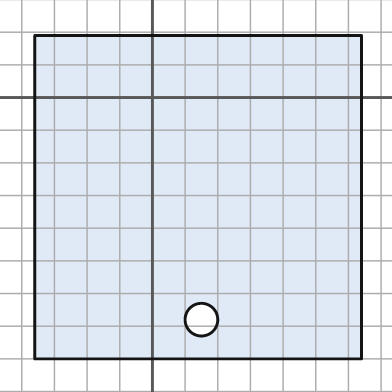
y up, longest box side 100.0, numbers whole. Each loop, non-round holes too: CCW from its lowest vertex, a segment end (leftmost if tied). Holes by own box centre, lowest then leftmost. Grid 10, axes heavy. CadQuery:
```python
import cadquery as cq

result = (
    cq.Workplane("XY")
    .moveTo(-36.0, -80.0)
    .lineTo(64.0, -80.0)
    .lineTo(64.0, 19.0)
    .lineTo(-36.0, 19.0)
    .close()
    .moveTo(15.0, -68.0)
    .circle(5.0)
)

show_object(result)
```